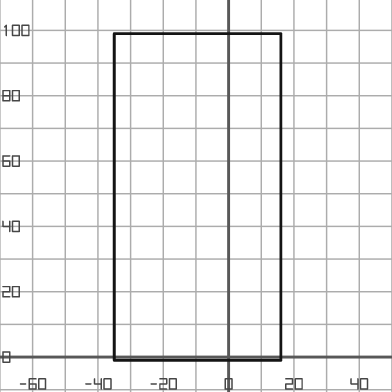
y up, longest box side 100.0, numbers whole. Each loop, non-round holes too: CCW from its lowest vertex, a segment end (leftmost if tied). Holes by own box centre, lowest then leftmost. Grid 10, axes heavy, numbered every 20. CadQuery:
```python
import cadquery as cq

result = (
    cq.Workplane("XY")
    .moveTo(-35.0, -1.0)
    .lineTo(16.0, -1.0)
    .lineTo(16.0, 99.0)
    .lineTo(-35.0, 99.0)
    .close()
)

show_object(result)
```